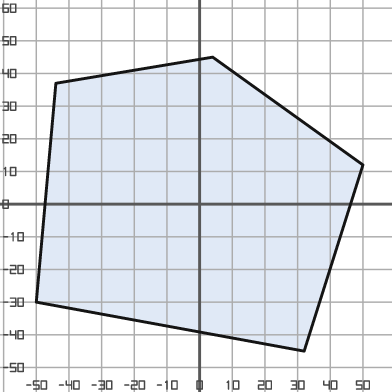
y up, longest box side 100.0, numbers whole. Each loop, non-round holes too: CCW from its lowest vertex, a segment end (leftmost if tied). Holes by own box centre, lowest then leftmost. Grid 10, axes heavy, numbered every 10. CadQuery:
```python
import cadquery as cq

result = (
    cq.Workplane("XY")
    .moveTo(32.0, -45.0)
    .lineTo(50.0, 12.0)
    .lineTo(4.0, 45.0)
    .lineTo(-44.0, 37.0)
    .lineTo(-50.0, -30.0)
    .close()
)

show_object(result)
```